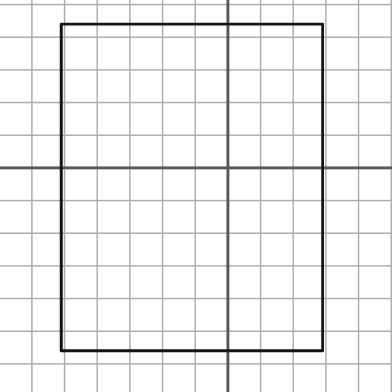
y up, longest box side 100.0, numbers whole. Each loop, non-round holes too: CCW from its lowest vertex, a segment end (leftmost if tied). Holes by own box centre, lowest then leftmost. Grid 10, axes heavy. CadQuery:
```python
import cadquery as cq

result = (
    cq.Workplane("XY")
    .moveTo(-51.0, -56.0)
    .lineTo(29.0, -56.0)
    .lineTo(29.0, 44.0)
    .lineTo(-51.0, 44.0)
    .close()
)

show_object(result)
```